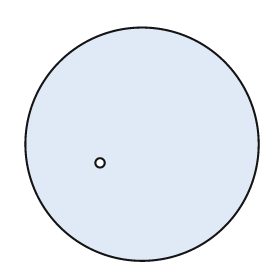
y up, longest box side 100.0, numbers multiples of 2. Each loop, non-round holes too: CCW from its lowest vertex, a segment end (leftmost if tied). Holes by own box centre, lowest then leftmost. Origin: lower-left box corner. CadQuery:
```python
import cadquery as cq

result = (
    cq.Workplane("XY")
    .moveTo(50.0, 50.0)
    .circle(50.0)
    .moveTo(32.0, 42.0)
    .circle(2.0)
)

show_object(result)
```